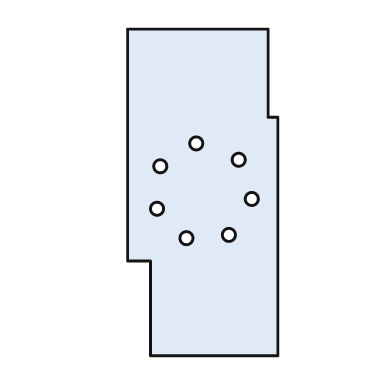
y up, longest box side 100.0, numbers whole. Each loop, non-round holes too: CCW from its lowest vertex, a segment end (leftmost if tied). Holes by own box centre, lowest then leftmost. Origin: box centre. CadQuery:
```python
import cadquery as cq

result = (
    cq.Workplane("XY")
    .moveTo(-16.0, -50.0)
    .lineTo(23.0, -50.0)
    .lineTo(23.0, 23.0)
    .lineTo(20.0, 23.0)
    .lineTo(20.0, 50.0)
    .lineTo(-23.0, 50.0)
    .lineTo(-23.0, -21.0)
    .lineTo(-16.0, -21.0)
    .close()
    .moveTo(-5.0, -14.0)
    .circle(2.0)
    .moveTo(8.0, -13.0)
    .circle(2.0)
    .moveTo(-14.0, -5.0)
    .circle(2.0)
    .moveTo(15.0, -2.0)
    .circle(2.0)
    .moveTo(-13.0, 8.0)
    .circle(2.0)
    .moveTo(11.0, 10.0)
    .circle(2.0)
    .moveTo(-2.0, 15.0)
    .circle(2.0)
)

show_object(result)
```